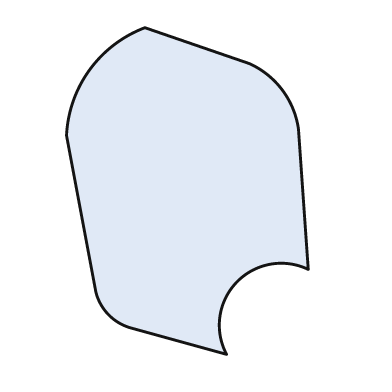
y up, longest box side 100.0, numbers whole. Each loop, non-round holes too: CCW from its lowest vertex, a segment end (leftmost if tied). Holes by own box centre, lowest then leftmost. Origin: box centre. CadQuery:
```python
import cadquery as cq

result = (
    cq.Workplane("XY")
    .moveTo(12.0, -50.0)
    .threePointArc((15.0, -28.0), (37.0, -24.0))
    .lineTo(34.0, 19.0)
    .threePointArc((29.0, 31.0), (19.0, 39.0))
    .lineTo(-13.0, 50.0)
    .threePointArc((-30.0, 37.0), (-37.0, 17.0))
    .lineTo(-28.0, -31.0)
    .threePointArc((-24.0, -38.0), (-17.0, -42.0))
    .close()
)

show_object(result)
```